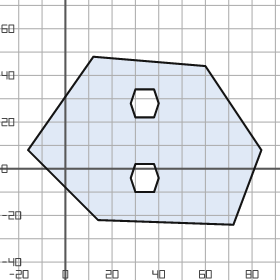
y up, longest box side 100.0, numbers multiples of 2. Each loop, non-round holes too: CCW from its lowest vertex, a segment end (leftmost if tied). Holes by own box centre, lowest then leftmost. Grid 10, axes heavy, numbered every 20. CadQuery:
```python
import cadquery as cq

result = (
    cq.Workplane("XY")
    .moveTo(72.0, -24.0)
    .lineTo(84.0, 8.0)
    .lineTo(60.0, 44.0)
    .lineTo(12.0, 48.0)
    .lineTo(-16.0, 8.0)
    .lineTo(14.0, -22.0)
    .close()
    .moveTo(30.0, -10.0)
    .lineTo(38.0, -10.0)
    .lineTo(40.0, -4.0)
    .lineTo(38.0, 2.0)
    .lineTo(30.0, 2.0)
    .lineTo(28.0, -4.0)
    .close()
    .moveTo(30.0, 22.0)
    .lineTo(38.0, 22.0)
    .lineTo(40.0, 28.0)
    .lineTo(38.0, 34.0)
    .lineTo(30.0, 34.0)
    .lineTo(28.0, 28.0)
    .close()
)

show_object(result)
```